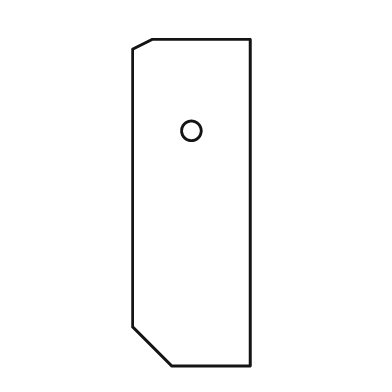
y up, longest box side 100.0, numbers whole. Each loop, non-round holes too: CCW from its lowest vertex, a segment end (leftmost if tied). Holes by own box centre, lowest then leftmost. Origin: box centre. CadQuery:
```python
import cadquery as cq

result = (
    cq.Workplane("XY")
    .moveTo(-6.0, -50.0)
    .lineTo(18.0, -50.0)
    .lineTo(18.0, 50.0)
    .lineTo(-12.0, 50.0)
    .lineTo(-18.0, 47.0)
    .lineTo(-18.0, -38.0)
    .close()
    .moveTo(0.0, 22.0)
    .circle(3.0)
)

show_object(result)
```